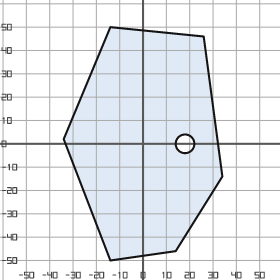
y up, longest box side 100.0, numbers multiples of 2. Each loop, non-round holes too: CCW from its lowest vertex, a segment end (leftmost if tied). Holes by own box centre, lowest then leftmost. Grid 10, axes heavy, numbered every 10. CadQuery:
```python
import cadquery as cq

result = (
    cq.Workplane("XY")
    .moveTo(-14.0, -50.0)
    .lineTo(14.0, -46.0)
    .lineTo(34.0, -14.0)
    .lineTo(26.0, 46.0)
    .lineTo(-14.0, 50.0)
    .lineTo(-34.0, 2.0)
    .close()
    .moveTo(18.0, 0.0)
    .circle(4.0)
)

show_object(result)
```